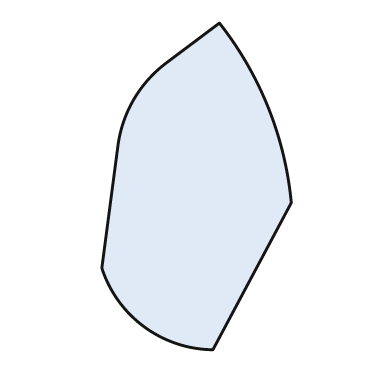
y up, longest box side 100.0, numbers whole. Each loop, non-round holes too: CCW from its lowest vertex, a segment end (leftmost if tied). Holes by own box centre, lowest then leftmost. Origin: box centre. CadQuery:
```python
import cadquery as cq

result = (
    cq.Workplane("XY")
    .moveTo(5.0, -50.0)
    .lineTo(29.0, -5.0)
    .threePointArc((22.0, 24.0), (7.0, 50.0))
    .lineTo(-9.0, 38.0)
    .threePointArc((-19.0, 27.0), (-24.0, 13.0))
    .lineTo(-29.0, -25.0)
    .threePointArc((-16.0, -43.0), (5.0, -50.0))
    .close()
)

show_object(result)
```